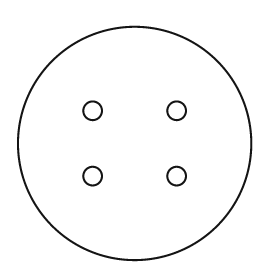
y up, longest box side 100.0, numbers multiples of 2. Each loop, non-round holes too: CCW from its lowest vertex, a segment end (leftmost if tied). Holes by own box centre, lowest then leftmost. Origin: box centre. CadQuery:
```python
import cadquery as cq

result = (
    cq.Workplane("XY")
    .moveTo(0.0, 0.0)
    .circle(50.0)
    .moveTo(-18.0, -14.0)
    .circle(4.0)
    .moveTo(18.0, -14.0)
    .circle(4.0)
    .moveTo(-18.0, 14.0)
    .circle(4.0)
    .moveTo(18.0, 14.0)
    .circle(4.0)
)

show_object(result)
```